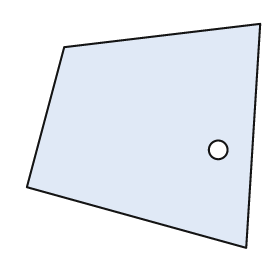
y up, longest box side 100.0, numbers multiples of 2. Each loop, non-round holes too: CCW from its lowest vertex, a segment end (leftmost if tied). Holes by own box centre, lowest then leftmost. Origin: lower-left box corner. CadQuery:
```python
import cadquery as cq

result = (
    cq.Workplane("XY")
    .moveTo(94.0, 0.0)
    .lineTo(100.0, 96.0)
    .lineTo(16.0, 86.0)
    .lineTo(0.0, 26.0)
    .close()
    .moveTo(82.0, 42.0)
    .circle(4.0)
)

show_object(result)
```